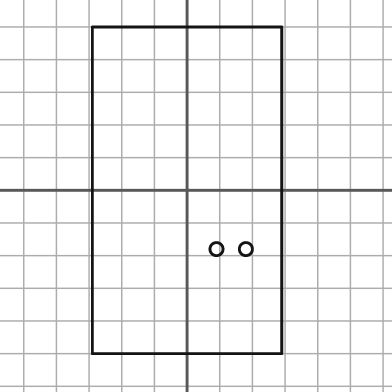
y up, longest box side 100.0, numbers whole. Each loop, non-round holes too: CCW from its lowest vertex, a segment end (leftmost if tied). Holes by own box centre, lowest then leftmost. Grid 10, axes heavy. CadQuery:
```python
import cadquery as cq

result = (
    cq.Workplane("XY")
    .moveTo(-29.0, -50.0)
    .lineTo(29.0, -50.0)
    .lineTo(29.0, 50.0)
    .lineTo(-29.0, 50.0)
    .close()
    .moveTo(9.0, -18.0)
    .circle(2.0)
    .moveTo(18.0, -18.0)
    .circle(2.0)
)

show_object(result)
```